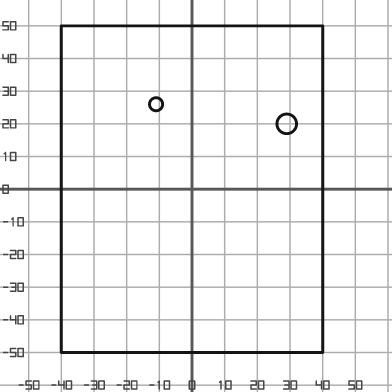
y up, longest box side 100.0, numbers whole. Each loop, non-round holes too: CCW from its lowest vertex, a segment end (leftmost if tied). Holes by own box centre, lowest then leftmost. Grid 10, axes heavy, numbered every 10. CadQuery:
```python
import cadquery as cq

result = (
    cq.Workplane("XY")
    .moveTo(-40.0, -50.0)
    .lineTo(40.0, -50.0)
    .lineTo(40.0, 50.0)
    .lineTo(-40.0, 50.0)
    .close()
    .moveTo(29.0, 20.0)
    .circle(3.0)
    .moveTo(-11.0, 26.0)
    .circle(2.0)
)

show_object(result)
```